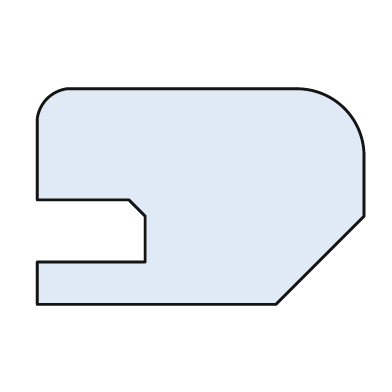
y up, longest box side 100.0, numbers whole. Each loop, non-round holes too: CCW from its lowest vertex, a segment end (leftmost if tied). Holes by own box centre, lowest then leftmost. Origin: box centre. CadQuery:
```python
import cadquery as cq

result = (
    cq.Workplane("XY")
    .moveTo(-50.0, -33.0)
    .lineTo(23.0, -33.0)
    .lineTo(50.0, -6.0)
    .lineTo(50.0, 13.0)
    .threePointArc((44.0, 27.0), (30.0, 33.0))
    .lineTo(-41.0, 33.0)
    .threePointArc((-47.0, 30.0), (-50.0, 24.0))
    .lineTo(-50.0, -1.0)
    .lineTo(-22.0, -1.0)
    .lineTo(-17.0, -6.0)
    .lineTo(-17.0, -20.0)
    .lineTo(-50.0, -20.0)
    .close()
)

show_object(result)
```